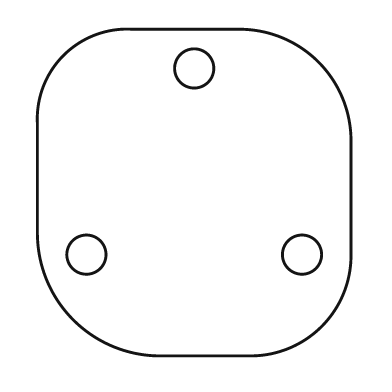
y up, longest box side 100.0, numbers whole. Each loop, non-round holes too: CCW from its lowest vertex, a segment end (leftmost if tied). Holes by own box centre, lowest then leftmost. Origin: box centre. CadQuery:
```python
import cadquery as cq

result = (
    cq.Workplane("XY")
    .moveTo(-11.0, -50.0)
    .lineTo(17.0, -50.0)
    .threePointArc((39.0, -41.0), (48.0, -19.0))
    .lineTo(48.0, 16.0)
    .threePointArc((38.0, 40.0), (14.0, 50.0))
    .lineTo(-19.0, 50.0)
    .threePointArc((-40.0, 42.0), (-48.0, 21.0))
    .lineTo(-48.0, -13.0)
    .threePointArc((-37.0, -39.0), (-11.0, -50.0))
    .close()
    .moveTo(-33.0, -19.0)
    .circle(6.0)
    .moveTo(33.0, -19.0)
    .circle(6.0)
    .moveTo(0.0, 38.0)
    .circle(6.0)
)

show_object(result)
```